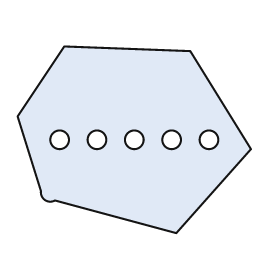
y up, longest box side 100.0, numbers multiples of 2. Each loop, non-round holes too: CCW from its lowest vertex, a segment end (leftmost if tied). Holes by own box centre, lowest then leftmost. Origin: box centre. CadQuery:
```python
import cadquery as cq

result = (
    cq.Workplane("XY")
    .moveTo(18.0, -40.0)
    .lineTo(50.0, -4.0)
    .lineTo(24.0, 38.0)
    .lineTo(-30.0, 40.0)
    .lineTo(-50.0, 10.0)
    .lineTo(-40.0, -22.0)
    .threePointArc((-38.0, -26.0), (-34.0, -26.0))
    .close()
    .moveTo(-32.0, 0.0)
    .circle(4.0)
    .moveTo(-16.0, 0.0)
    .circle(4.0)
    .moveTo(0.0, 0.0)
    .circle(4.0)
    .moveTo(16.0, 0.0)
    .circle(4.0)
    .moveTo(32.0, 0.0)
    .circle(4.0)
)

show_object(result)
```